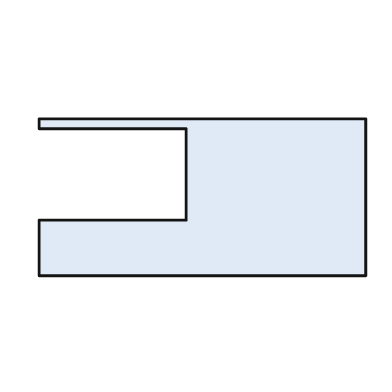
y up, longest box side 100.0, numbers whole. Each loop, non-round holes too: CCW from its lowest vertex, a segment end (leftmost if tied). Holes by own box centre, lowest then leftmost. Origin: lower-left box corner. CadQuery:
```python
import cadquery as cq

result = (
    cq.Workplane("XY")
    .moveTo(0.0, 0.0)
    .lineTo(100.0, 0.0)
    .lineTo(100.0, 48.0)
    .lineTo(0.0, 48.0)
    .lineTo(0.0, 45.0)
    .lineTo(45.0, 45.0)
    .lineTo(45.0, 17.0)
    .lineTo(0.0, 17.0)
    .close()
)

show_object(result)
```